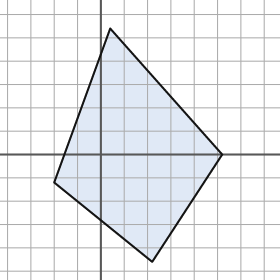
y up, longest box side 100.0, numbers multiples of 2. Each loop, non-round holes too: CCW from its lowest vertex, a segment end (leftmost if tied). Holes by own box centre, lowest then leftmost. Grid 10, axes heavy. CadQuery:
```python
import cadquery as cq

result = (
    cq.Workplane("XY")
    .moveTo(22.0, -46.0)
    .lineTo(52.0, 0.0)
    .lineTo(4.0, 54.0)
    .lineTo(-20.0, -12.0)
    .close()
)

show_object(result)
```